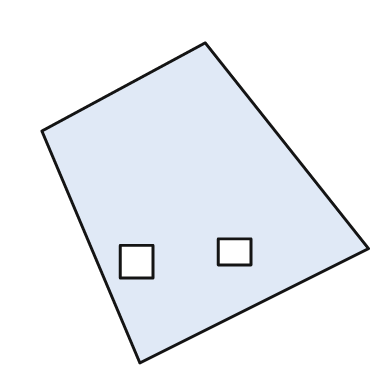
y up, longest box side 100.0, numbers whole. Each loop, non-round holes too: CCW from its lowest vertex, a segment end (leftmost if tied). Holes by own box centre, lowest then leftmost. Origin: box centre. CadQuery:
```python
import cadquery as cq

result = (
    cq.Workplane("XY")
    .moveTo(-20.0, -49.0)
    .lineTo(50.0, -14.0)
    .lineTo(0.0, 49.0)
    .lineTo(-50.0, 22.0)
    .close()
    .moveTo(-26.0, -23.0)
    .lineTo(-16.0, -23.0)
    .lineTo(-16.0, -13.0)
    .lineTo(-26.0, -13.0)
    .close()
    .moveTo(4.0, -19.0)
    .lineTo(14.0, -19.0)
    .lineTo(14.0, -11.0)
    .lineTo(4.0, -11.0)
    .close()
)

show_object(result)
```